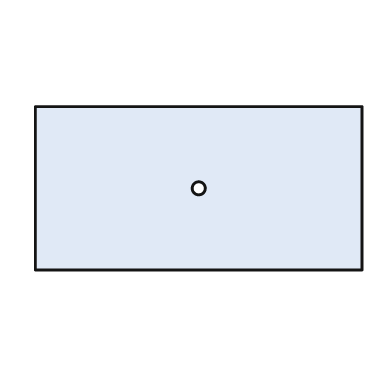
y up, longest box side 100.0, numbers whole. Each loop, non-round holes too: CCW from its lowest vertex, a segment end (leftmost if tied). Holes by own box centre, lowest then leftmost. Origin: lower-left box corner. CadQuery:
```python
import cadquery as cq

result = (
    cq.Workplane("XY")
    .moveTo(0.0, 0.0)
    .lineTo(100.0, 0.0)
    .lineTo(100.0, 50.0)
    .lineTo(0.0, 50.0)
    .close()
    .moveTo(50.0, 25.0)
    .circle(2.0)
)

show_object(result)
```